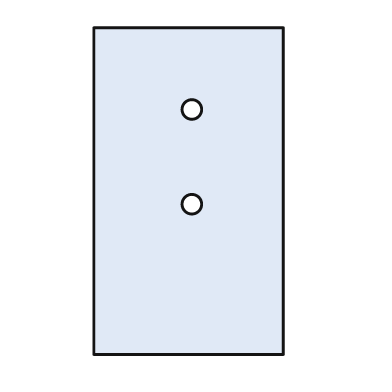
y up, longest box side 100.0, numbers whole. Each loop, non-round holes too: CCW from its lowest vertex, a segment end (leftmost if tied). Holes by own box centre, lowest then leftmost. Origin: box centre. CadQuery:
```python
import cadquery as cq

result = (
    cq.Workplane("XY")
    .moveTo(-29.0, -50.0)
    .lineTo(29.0, -50.0)
    .lineTo(29.0, 50.0)
    .lineTo(-29.0, 50.0)
    .close()
    .moveTo(1.0, -4.0)
    .circle(3.0)
    .moveTo(1.0, 25.0)
    .circle(3.0)
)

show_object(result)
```